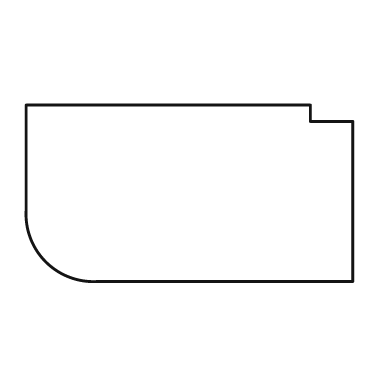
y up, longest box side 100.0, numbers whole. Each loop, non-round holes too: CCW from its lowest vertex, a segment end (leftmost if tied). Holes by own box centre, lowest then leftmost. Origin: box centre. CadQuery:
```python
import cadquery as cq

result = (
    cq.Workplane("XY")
    .moveTo(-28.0, -27.0)
    .lineTo(50.0, -27.0)
    .lineTo(50.0, 22.0)
    .lineTo(37.0, 22.0)
    .lineTo(37.0, 27.0)
    .lineTo(-50.0, 27.0)
    .lineTo(-50.0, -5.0)
    .threePointArc((-44.0, -21.0), (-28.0, -27.0))
    .close()
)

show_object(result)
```